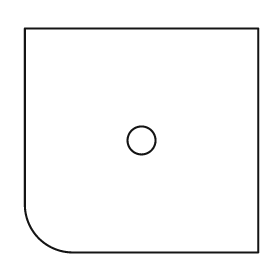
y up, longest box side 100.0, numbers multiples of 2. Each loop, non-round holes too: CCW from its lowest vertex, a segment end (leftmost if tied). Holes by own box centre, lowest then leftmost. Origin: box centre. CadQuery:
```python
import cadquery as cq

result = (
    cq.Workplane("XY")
    .moveTo(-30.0, -48.0)
    .lineTo(50.0, -48.0)
    .lineTo(50.0, 48.0)
    .lineTo(-50.0, 48.0)
    .lineTo(-50.0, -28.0)
    .threePointArc((-44.0, -42.0), (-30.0, -48.0))
    .close()
    .moveTo(0.0, 0.0)
    .circle(6.0)
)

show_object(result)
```